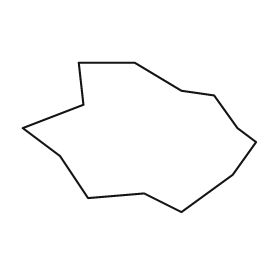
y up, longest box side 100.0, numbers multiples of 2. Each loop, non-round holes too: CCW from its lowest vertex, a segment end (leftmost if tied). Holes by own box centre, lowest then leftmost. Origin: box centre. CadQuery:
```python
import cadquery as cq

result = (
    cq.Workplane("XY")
    .moveTo(18.0, -32.0)
    .lineTo(40.0, -16.0)
    .lineTo(50.0, -2.0)
    .lineTo(42.0, 4.0)
    .lineTo(32.0, 18.0)
    .lineTo(18.0, 20.0)
    .lineTo(-2.0, 32.0)
    .lineTo(-26.0, 32.0)
    .lineTo(-24.0, 14.0)
    .lineTo(-50.0, 4.0)
    .lineTo(-34.0, -8.0)
    .lineTo(-22.0, -26.0)
    .lineTo(2.0, -24.0)
    .close()
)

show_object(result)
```